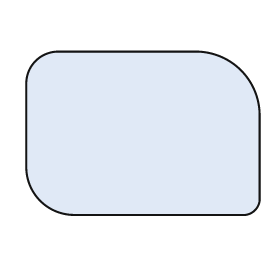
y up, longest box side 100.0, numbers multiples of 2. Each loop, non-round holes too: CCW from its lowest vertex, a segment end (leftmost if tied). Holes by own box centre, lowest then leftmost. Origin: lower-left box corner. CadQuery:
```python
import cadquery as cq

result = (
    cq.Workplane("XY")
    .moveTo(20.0, 0.0)
    .lineTo(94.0, 0.0)
    .threePointArc((98.0, 2.0), (100.0, 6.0))
    .lineTo(100.0, 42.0)
    .threePointArc((92.0, 62.0), (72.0, 70.0))
    .lineTo(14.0, 70.0)
    .threePointArc((4.0, 66.0), (0.0, 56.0))
    .lineTo(0.0, 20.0)
    .threePointArc((6.0, 6.0), (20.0, 0.0))
    .close()
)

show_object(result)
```